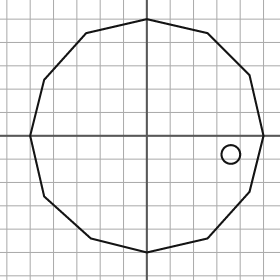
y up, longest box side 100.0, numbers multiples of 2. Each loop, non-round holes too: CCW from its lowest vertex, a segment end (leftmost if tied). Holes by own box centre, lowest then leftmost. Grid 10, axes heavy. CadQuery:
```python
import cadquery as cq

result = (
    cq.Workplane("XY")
    .moveTo(0.0, -50.0)
    .lineTo(26.0, -44.0)
    .lineTo(44.0, -24.0)
    .lineTo(50.0, 0.0)
    .lineTo(44.0, 26.0)
    .lineTo(26.0, 44.0)
    .lineTo(0.0, 50.0)
    .lineTo(-26.0, 44.0)
    .lineTo(-44.0, 24.0)
    .lineTo(-50.0, 0.0)
    .lineTo(-44.0, -26.0)
    .lineTo(-24.0, -44.0)
    .close()
    .moveTo(36.0, -8.0)
    .circle(4.0)
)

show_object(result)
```